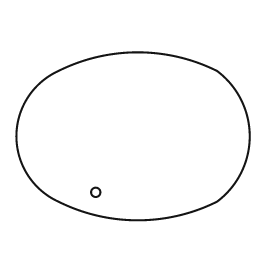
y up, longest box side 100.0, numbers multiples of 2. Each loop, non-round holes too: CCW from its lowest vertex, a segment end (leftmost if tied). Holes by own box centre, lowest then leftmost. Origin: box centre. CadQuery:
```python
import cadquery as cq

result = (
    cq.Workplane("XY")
    .moveTo(-32.0, -28.0)
    .threePointArc((2.0, -36.0), (36.0, -28.0))
    .threePointArc((50.0, 0.0), (36.0, 28.0))
    .threePointArc((2.0, 36.0), (-32.0, 28.0))
    .threePointArc((-50.0, 0.0), (-32.0, -28.0))
    .close()
    .moveTo(-16.0, -24.0)
    .circle(2.0)
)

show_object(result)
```